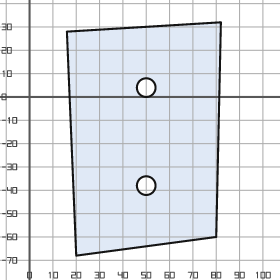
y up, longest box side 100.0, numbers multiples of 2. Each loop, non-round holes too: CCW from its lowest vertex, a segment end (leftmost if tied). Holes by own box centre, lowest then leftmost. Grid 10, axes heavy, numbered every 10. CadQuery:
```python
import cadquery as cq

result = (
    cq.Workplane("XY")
    .moveTo(20.0, -68.0)
    .lineTo(80.0, -60.0)
    .lineTo(82.0, 32.0)
    .lineTo(16.0, 28.0)
    .close()
    .moveTo(50.0, -38.0)
    .circle(4.0)
    .moveTo(50.0, 4.0)
    .circle(4.0)
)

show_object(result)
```